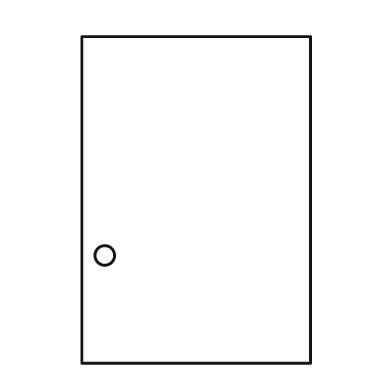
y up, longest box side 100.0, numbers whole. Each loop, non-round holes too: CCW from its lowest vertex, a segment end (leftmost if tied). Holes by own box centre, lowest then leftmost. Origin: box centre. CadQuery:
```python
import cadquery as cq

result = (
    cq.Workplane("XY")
    .moveTo(-35.0, -50.0)
    .lineTo(35.0, -50.0)
    .lineTo(35.0, 50.0)
    .lineTo(-35.0, 50.0)
    .close()
    .moveTo(-28.0, -17.0)
    .circle(3.0)
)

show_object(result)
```